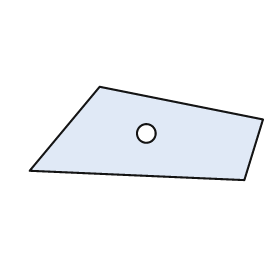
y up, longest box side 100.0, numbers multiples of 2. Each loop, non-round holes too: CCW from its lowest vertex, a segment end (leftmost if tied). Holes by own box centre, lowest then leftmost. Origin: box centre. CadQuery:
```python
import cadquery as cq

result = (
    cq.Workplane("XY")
    .moveTo(42.0, -20.0)
    .lineTo(50.0, 6.0)
    .lineTo(-20.0, 20.0)
    .lineTo(-50.0, -16.0)
    .close()
    .moveTo(0.0, 0.0)
    .circle(4.0)
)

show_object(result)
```